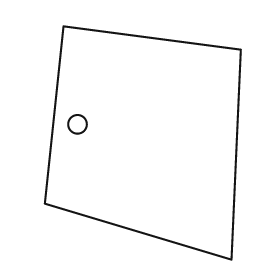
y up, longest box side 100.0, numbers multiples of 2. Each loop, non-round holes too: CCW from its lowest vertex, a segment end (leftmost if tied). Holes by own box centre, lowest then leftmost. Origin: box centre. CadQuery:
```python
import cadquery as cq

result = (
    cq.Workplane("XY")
    .moveTo(38.0, -50.0)
    .lineTo(42.0, 40.0)
    .lineTo(-34.0, 50.0)
    .lineTo(-42.0, -26.0)
    .close()
    .moveTo(-28.0, 8.0)
    .circle(4.0)
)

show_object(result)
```